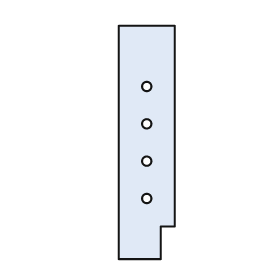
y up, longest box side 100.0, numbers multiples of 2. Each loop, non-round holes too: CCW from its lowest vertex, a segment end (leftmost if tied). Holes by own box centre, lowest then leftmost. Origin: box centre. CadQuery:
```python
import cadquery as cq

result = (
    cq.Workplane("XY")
    .moveTo(-12.0, -50.0)
    .lineTo(6.0, -50.0)
    .lineTo(6.0, -36.0)
    .lineTo(12.0, -36.0)
    .lineTo(12.0, 50.0)
    .lineTo(-12.0, 50.0)
    .close()
    .moveTo(0.0, -24.0)
    .circle(2.0)
    .moveTo(0.0, -8.0)
    .circle(2.0)
    .moveTo(0.0, 8.0)
    .circle(2.0)
    .moveTo(0.0, 24.0)
    .circle(2.0)
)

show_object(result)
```